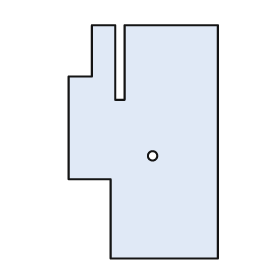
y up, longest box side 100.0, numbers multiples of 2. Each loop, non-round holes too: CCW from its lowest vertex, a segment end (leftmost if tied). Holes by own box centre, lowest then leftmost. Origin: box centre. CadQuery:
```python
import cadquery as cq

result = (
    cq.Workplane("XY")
    .moveTo(-14.0, -50.0)
    .lineTo(32.0, -50.0)
    .lineTo(32.0, 50.0)
    .lineTo(-8.0, 50.0)
    .lineTo(-8.0, 18.0)
    .lineTo(-12.0, 18.0)
    .lineTo(-12.0, 50.0)
    .lineTo(-22.0, 50.0)
    .lineTo(-22.0, 28.0)
    .lineTo(-32.0, 28.0)
    .lineTo(-32.0, -16.0)
    .lineTo(-14.0, -16.0)
    .close()
    .moveTo(4.0, -6.0)
    .circle(2.0)
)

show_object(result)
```